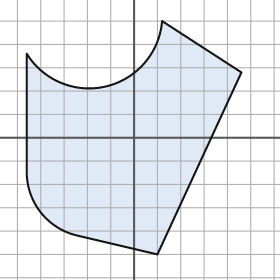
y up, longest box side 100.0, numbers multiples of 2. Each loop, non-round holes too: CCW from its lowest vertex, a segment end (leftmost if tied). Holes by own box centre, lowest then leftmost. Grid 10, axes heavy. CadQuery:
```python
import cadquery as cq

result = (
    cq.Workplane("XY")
    .moveTo(10.0, -50.0)
    .lineTo(46.0, 28.0)
    .lineTo(12.0, 50.0)
    .threePointArc((-12.0, 22.0), (-46.0, 36.0))
    .lineTo(-46.0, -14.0)
    .threePointArc((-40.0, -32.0), (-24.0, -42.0))
    .close()
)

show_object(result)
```